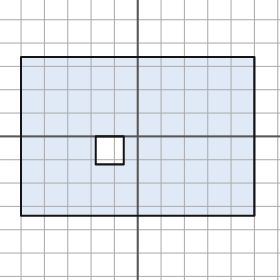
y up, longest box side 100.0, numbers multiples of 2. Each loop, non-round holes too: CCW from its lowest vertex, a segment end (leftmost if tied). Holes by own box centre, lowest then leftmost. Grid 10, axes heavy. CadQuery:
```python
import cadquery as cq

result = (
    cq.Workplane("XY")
    .moveTo(-50.0, -34.0)
    .lineTo(50.0, -34.0)
    .lineTo(50.0, 34.0)
    .lineTo(-50.0, 34.0)
    .close()
    .moveTo(-18.0, -12.0)
    .lineTo(-6.0, -12.0)
    .lineTo(-6.0, 0.0)
    .lineTo(-18.0, 0.0)
    .close()
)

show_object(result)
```